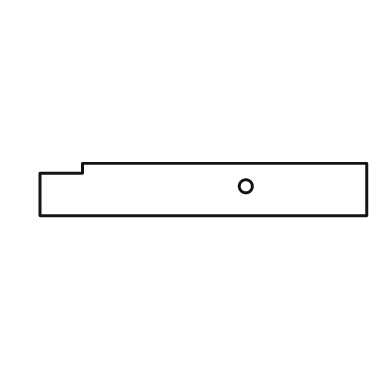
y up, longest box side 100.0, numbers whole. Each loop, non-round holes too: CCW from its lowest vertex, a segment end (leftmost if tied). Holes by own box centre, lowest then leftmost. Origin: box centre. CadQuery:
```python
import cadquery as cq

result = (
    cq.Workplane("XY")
    .moveTo(-50.0, -8.0)
    .lineTo(50.0, -8.0)
    .lineTo(50.0, 8.0)
    .lineTo(-37.0, 8.0)
    .lineTo(-37.0, 5.0)
    .lineTo(-50.0, 5.0)
    .close()
    .moveTo(13.0, 1.0)
    .circle(2.0)
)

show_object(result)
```